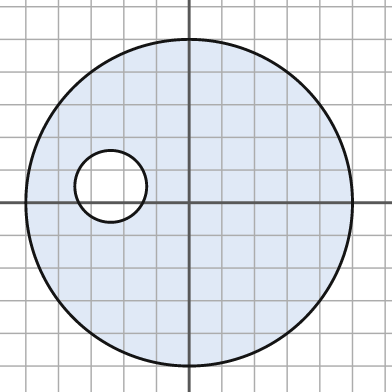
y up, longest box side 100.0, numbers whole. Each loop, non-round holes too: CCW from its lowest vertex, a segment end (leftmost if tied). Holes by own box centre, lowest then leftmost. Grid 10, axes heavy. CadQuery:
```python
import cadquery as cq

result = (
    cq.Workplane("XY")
    .moveTo(0.0, 0.0)
    .circle(50.0)
    .moveTo(-24.0, 5.0)
    .circle(11.0)
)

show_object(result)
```